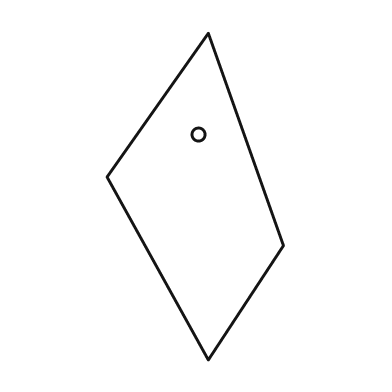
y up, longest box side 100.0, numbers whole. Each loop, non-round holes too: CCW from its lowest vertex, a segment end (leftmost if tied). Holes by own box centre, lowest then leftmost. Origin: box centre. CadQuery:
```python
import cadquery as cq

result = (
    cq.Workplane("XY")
    .moveTo(4.0, -50.0)
    .lineTo(27.0, -15.0)
    .lineTo(4.0, 50.0)
    .lineTo(-27.0, 6.0)
    .close()
    .moveTo(1.0, 19.0)
    .circle(2.0)
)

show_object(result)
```